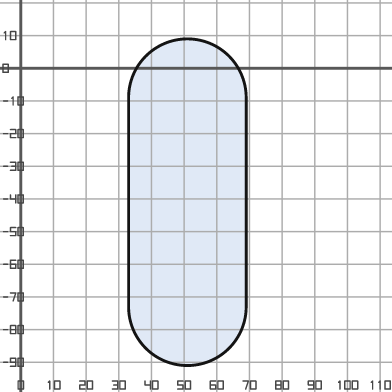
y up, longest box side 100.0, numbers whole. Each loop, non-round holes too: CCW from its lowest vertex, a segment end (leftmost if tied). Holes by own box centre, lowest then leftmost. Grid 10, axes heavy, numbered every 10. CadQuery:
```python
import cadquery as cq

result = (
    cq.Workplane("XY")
    .moveTo(33.0, -73.0)
    .threePointArc((51.0, -91.0), (69.0, -73.0))
    .lineTo(69.0, -9.0)
    .threePointArc((51.0, 9.0), (33.0, -9.0))
    .close()
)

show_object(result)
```